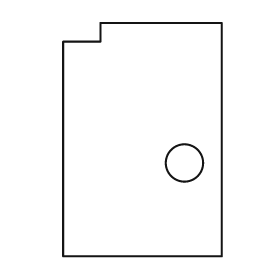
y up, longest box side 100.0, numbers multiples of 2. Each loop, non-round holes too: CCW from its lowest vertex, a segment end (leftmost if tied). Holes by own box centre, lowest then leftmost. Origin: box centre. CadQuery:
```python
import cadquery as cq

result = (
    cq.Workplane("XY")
    .moveTo(-34.0, -50.0)
    .lineTo(34.0, -50.0)
    .lineTo(34.0, 50.0)
    .lineTo(-18.0, 50.0)
    .lineTo(-18.0, 42.0)
    .lineTo(-34.0, 42.0)
    .close()
    .moveTo(18.0, -10.0)
    .circle(8.0)
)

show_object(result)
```